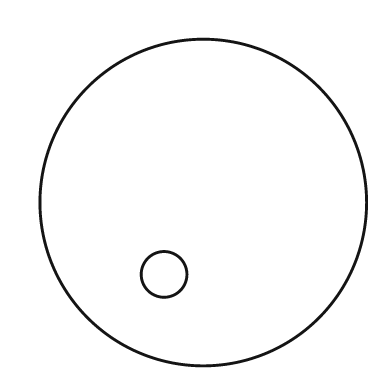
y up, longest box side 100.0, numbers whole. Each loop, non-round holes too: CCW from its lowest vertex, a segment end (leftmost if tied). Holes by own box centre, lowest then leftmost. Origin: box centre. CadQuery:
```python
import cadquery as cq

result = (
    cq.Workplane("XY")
    .moveTo(0.0, 0.0)
    .circle(50.0)
    .moveTo(-12.0, -22.0)
    .circle(7.0)
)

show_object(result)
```